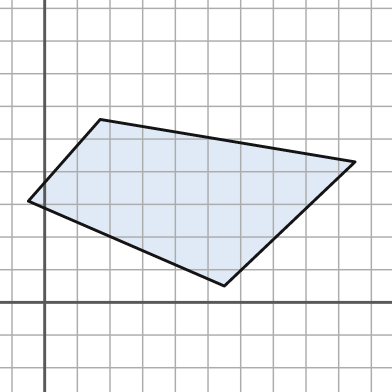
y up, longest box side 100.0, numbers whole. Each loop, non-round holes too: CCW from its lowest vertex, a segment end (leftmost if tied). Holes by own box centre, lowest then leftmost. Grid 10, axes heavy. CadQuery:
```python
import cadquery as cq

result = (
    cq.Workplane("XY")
    .moveTo(55.0, 5.0)
    .lineTo(95.0, 43.0)
    .lineTo(17.0, 56.0)
    .lineTo(-5.0, 31.0)
    .close()
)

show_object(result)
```